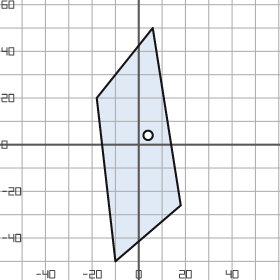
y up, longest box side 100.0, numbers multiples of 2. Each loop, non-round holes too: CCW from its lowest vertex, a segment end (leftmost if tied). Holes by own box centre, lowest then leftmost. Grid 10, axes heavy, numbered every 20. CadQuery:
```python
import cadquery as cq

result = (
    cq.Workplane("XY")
    .moveTo(-10.0, -50.0)
    .lineTo(18.0, -26.0)
    .lineTo(6.0, 50.0)
    .lineTo(-18.0, 20.0)
    .close()
    .moveTo(4.0, 4.0)
    .circle(2.0)
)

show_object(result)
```